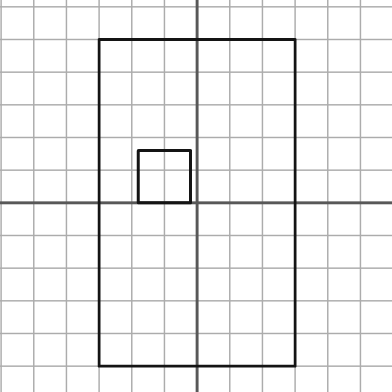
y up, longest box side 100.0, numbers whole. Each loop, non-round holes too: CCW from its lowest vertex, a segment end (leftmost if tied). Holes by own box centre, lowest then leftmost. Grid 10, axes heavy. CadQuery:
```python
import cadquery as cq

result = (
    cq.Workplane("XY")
    .moveTo(-30.0, -50.0)
    .lineTo(30.0, -50.0)
    .lineTo(30.0, 50.0)
    .lineTo(-30.0, 50.0)
    .close()
    .moveTo(-18.0, 0.0)
    .lineTo(-2.0, 0.0)
    .lineTo(-2.0, 16.0)
    .lineTo(-18.0, 16.0)
    .close()
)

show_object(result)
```